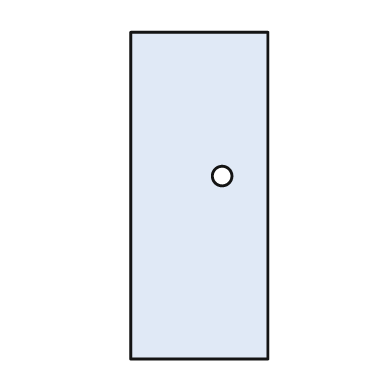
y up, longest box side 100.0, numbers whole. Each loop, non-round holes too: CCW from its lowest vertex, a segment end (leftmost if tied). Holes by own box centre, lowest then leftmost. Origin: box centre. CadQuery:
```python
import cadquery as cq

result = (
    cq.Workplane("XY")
    .moveTo(-21.0, -50.0)
    .lineTo(21.0, -50.0)
    .lineTo(21.0, 50.0)
    .lineTo(-21.0, 50.0)
    .close()
    .moveTo(7.0, 6.0)
    .circle(3.0)
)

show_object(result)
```